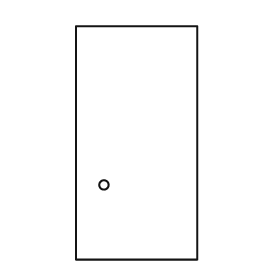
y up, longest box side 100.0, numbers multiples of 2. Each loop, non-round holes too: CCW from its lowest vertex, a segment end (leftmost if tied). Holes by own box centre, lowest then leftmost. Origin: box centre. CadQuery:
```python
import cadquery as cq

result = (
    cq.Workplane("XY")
    .moveTo(-26.0, -50.0)
    .lineTo(26.0, -50.0)
    .lineTo(26.0, 50.0)
    .lineTo(-26.0, 50.0)
    .close()
    .moveTo(-14.0, -18.0)
    .circle(2.0)
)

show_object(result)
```